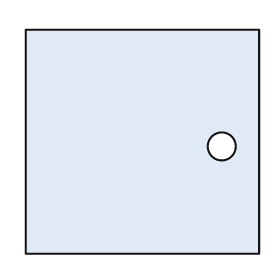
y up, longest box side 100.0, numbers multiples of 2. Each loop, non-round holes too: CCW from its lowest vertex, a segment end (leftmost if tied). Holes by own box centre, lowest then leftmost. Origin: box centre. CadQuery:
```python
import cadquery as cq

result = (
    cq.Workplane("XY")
    .moveTo(-50.0, -48.0)
    .lineTo(50.0, -48.0)
    .lineTo(50.0, 48.0)
    .lineTo(-50.0, 48.0)
    .close()
    .moveTo(34.0, -2.0)
    .circle(6.0)
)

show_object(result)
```